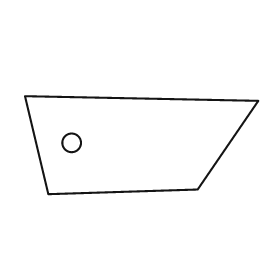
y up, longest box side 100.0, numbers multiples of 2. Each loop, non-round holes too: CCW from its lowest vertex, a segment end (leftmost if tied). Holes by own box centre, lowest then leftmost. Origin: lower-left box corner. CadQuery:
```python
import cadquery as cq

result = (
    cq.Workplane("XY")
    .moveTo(10.0, 0.0)
    .lineTo(74.0, 2.0)
    .lineTo(100.0, 40.0)
    .lineTo(0.0, 42.0)
    .close()
    .moveTo(20.0, 22.0)
    .circle(4.0)
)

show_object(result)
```